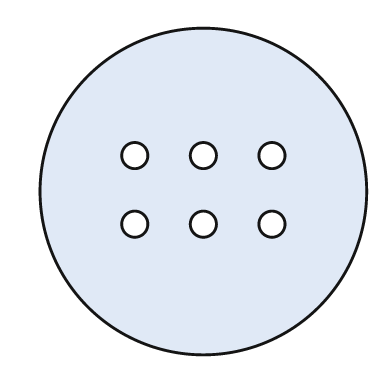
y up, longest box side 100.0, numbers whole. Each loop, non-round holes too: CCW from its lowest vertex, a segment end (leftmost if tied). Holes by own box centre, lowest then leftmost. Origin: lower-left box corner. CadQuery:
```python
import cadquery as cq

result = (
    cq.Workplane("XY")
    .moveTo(50.0, 50.0)
    .circle(50.0)
    .moveTo(29.0, 40.0)
    .circle(4.0)
    .moveTo(50.0, 40.0)
    .circle(4.0)
    .moveTo(71.0, 40.0)
    .circle(4.0)
    .moveTo(29.0, 61.0)
    .circle(4.0)
    .moveTo(50.0, 61.0)
    .circle(4.0)
    .moveTo(71.0, 61.0)
    .circle(4.0)
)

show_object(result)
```